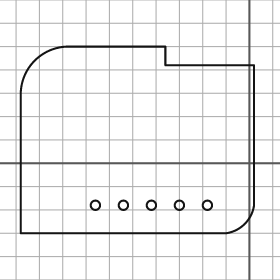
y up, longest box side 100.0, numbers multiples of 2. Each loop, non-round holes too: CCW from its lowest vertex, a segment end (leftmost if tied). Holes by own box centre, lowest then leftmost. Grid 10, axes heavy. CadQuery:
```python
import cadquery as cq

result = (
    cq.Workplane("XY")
    .moveTo(-98.0, -30.0)
    .lineTo(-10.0, -30.0)
    .threePointArc((-2.0, -26.0), (2.0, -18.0))
    .lineTo(2.0, 42.0)
    .lineTo(-36.0, 42.0)
    .lineTo(-36.0, 50.0)
    .lineTo(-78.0, 50.0)
    .threePointArc((-92.0, 44.0), (-98.0, 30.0))
    .close()
    .moveTo(-66.0, -18.0)
    .circle(2.0)
    .moveTo(-54.0, -18.0)
    .circle(2.0)
    .moveTo(-42.0, -18.0)
    .circle(2.0)
    .moveTo(-30.0, -18.0)
    .circle(2.0)
    .moveTo(-18.0, -18.0)
    .circle(2.0)
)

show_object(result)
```